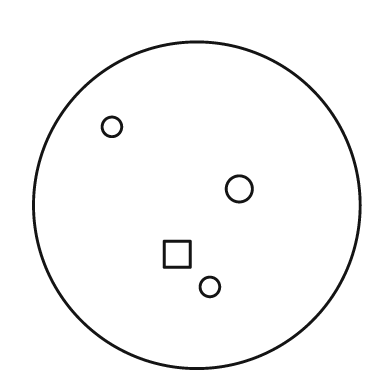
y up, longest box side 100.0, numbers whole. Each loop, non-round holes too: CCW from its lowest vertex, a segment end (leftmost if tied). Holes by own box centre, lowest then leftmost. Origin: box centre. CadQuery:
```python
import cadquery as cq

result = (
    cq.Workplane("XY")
    .moveTo(0.0, 0.0)
    .circle(50.0)
    .moveTo(4.0, -25.0)
    .circle(3.0)
    .moveTo(-10.0, -19.0)
    .lineTo(-2.0, -19.0)
    .lineTo(-2.0, -11.0)
    .lineTo(-10.0, -11.0)
    .close()
    .moveTo(13.0, 5.0)
    .circle(4.0)
    .moveTo(-26.0, 24.0)
    .circle(3.0)
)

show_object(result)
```